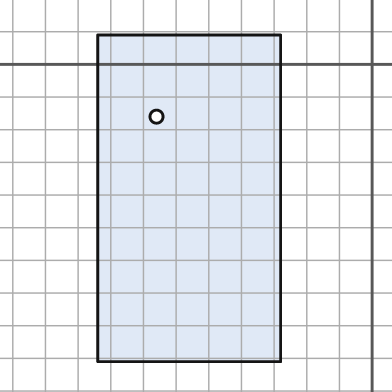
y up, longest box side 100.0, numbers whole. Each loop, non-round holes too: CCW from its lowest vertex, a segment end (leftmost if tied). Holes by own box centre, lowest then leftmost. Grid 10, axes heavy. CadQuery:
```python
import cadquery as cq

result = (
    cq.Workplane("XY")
    .moveTo(-84.0, -91.0)
    .lineTo(-28.0, -91.0)
    .lineTo(-28.0, 9.0)
    .lineTo(-84.0, 9.0)
    .close()
    .moveTo(-66.0, -16.0)
    .circle(2.0)
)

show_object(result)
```